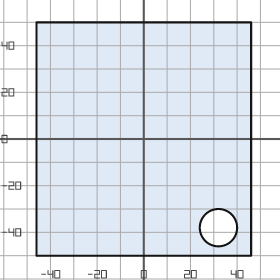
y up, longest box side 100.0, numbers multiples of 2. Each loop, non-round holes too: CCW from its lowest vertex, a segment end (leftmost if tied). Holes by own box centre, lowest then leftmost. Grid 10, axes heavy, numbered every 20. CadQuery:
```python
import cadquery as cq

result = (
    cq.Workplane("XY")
    .moveTo(-46.0, -50.0)
    .lineTo(46.0, -50.0)
    .lineTo(46.0, 50.0)
    .lineTo(-46.0, 50.0)
    .close()
    .moveTo(32.0, -38.0)
    .circle(8.0)
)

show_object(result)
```